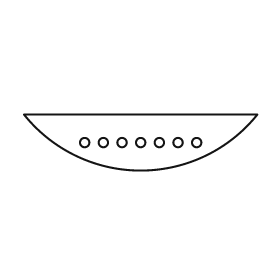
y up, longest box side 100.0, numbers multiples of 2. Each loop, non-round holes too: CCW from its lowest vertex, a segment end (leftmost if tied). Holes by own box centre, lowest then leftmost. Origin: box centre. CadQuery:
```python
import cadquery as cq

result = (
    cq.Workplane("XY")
    .moveTo(-50.0, 12.0)
    .threePointArc((0.0, -12.0), (50.0, 12.0))
    .close()
    .moveTo(-24.0, 0.0)
    .circle(2.0)
    .moveTo(-16.0, 0.0)
    .circle(2.0)
    .moveTo(-8.0, 0.0)
    .circle(2.0)
    .moveTo(0.0, 0.0)
    .circle(2.0)
    .moveTo(8.0, 0.0)
    .circle(2.0)
    .moveTo(16.0, 0.0)
    .circle(2.0)
    .moveTo(24.0, 0.0)
    .circle(2.0)
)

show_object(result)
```